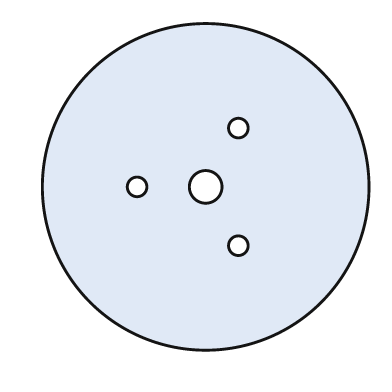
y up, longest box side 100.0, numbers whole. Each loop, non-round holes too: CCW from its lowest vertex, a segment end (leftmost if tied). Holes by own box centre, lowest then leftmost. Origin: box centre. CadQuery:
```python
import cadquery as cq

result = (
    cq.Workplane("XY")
    .moveTo(0.0, 0.0)
    .circle(50.0)
    .moveTo(10.0, -18.0)
    .circle(3.0)
    .moveTo(-21.0, 0.0)
    .circle(3.0)
    .moveTo(0.0, 0.0)
    .circle(5.0)
    .moveTo(10.0, 18.0)
    .circle(3.0)
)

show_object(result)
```